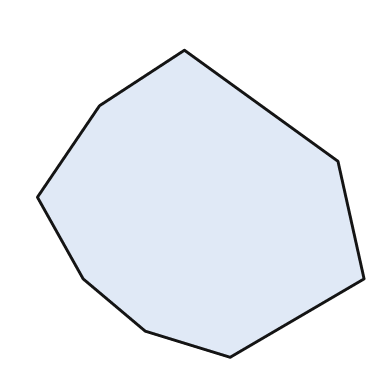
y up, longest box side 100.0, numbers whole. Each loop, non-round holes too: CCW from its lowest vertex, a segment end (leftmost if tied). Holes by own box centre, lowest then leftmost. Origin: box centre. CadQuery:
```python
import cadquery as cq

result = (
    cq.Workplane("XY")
    .moveTo(9.0, -47.0)
    .lineTo(50.0, -23.0)
    .lineTo(42.0, 13.0)
    .lineTo(-5.0, 47.0)
    .lineTo(-31.0, 30.0)
    .lineTo(-50.0, 2.0)
    .lineTo(-36.0, -23.0)
    .lineTo(-17.0, -39.0)
    .close()
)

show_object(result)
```